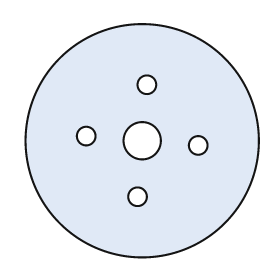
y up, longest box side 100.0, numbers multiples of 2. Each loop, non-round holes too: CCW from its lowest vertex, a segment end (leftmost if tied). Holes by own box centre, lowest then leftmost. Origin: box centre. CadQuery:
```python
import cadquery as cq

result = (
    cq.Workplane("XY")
    .moveTo(0.0, 0.0)
    .circle(50.0)
    .moveTo(-2.0, -24.0)
    .circle(4.0)
    .moveTo(24.0, -2.0)
    .circle(4.0)
    .moveTo(0.0, 0.0)
    .circle(8.0)
    .moveTo(-24.0, 2.0)
    .circle(4.0)
    .moveTo(2.0, 24.0)
    .circle(4.0)
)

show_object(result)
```